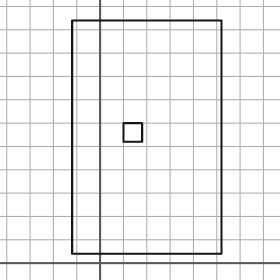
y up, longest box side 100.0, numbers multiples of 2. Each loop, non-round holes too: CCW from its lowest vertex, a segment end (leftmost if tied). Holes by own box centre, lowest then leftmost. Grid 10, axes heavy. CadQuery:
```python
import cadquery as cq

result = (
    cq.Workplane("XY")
    .moveTo(-12.0, 4.0)
    .lineTo(52.0, 4.0)
    .lineTo(52.0, 104.0)
    .lineTo(-12.0, 104.0)
    .close()
    .moveTo(10.0, 52.0)
    .lineTo(18.0, 52.0)
    .lineTo(18.0, 60.0)
    .lineTo(10.0, 60.0)
    .close()
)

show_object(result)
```